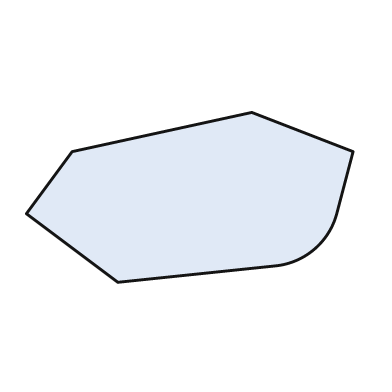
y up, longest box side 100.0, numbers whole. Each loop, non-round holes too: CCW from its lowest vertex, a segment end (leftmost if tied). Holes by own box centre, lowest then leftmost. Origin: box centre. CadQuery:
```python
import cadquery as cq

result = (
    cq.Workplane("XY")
    .moveTo(-22.0, -26.0)
    .lineTo(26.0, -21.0)
    .threePointArc((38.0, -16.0), (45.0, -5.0))
    .lineTo(50.0, 14.0)
    .lineTo(19.0, 26.0)
    .lineTo(-36.0, 14.0)
    .lineTo(-50.0, -5.0)
    .close()
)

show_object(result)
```